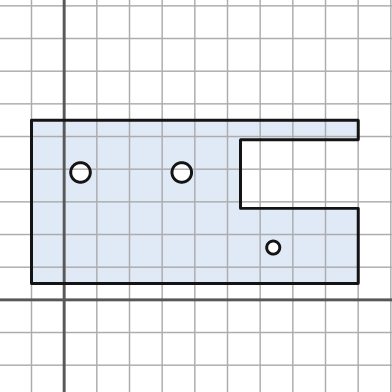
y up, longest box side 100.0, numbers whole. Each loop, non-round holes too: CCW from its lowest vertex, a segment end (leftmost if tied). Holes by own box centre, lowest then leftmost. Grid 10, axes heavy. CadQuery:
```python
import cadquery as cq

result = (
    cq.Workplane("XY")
    .moveTo(-10.0, 5.0)
    .lineTo(90.0, 5.0)
    .lineTo(90.0, 28.0)
    .lineTo(54.0, 28.0)
    .lineTo(54.0, 49.0)
    .lineTo(90.0, 49.0)
    .lineTo(90.0, 55.0)
    .lineTo(-10.0, 55.0)
    .close()
    .moveTo(64.0, 16.0)
    .circle(2.0)
    .moveTo(5.0, 39.0)
    .circle(3.0)
    .moveTo(36.0, 39.0)
    .circle(3.0)
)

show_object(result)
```